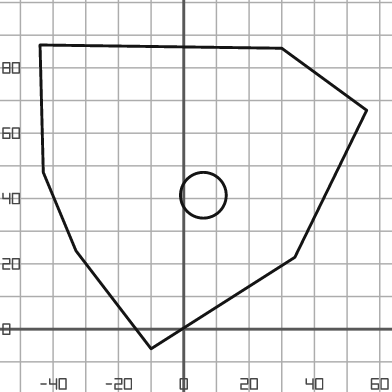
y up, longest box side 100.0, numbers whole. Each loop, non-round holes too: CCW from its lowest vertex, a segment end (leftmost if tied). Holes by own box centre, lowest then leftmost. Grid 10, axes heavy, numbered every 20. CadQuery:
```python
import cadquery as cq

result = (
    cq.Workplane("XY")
    .moveTo(-10.0, -6.0)
    .lineTo(34.0, 22.0)
    .lineTo(56.0, 67.0)
    .lineTo(30.0, 86.0)
    .lineTo(-44.0, 87.0)
    .lineTo(-43.0, 48.0)
    .lineTo(-33.0, 24.0)
    .close()
    .moveTo(6.0, 41.0)
    .circle(7.0)
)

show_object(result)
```